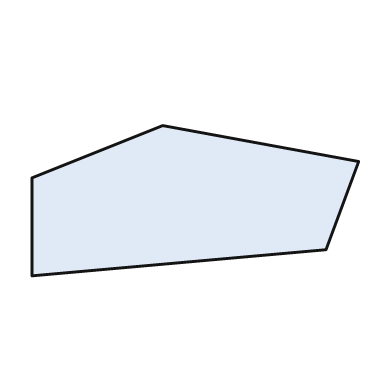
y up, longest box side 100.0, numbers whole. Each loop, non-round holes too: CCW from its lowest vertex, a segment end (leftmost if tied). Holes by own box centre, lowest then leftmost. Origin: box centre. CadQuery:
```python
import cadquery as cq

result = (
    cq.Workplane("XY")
    .moveTo(-50.0, -23.0)
    .lineTo(40.0, -15.0)
    .lineTo(50.0, 12.0)
    .lineTo(-10.0, 23.0)
    .lineTo(-50.0, 7.0)
    .close()
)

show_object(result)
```